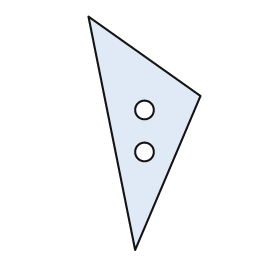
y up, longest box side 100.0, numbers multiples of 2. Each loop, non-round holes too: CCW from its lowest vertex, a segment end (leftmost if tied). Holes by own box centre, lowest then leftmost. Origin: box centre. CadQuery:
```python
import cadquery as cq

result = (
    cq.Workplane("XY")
    .moveTo(-4.0, -50.0)
    .lineTo(24.0, 16.0)
    .lineTo(-24.0, 50.0)
    .close()
    .moveTo(0.0, -8.0)
    .circle(4.0)
    .moveTo(0.0, 10.0)
    .circle(4.0)
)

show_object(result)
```